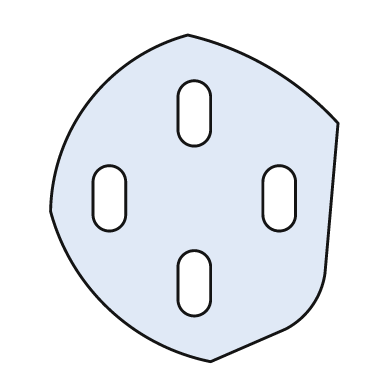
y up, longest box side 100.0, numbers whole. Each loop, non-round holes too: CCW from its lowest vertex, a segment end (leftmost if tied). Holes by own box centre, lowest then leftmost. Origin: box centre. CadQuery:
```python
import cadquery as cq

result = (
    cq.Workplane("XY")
    .moveTo(5.0, -50.0)
    .lineTo(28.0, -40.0)
    .threePointArc((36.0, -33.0), (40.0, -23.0))
    .lineTo(44.0, 23.0)
    .threePointArc((23.0, 40.0), (-2.0, 50.0))
    .threePointArc((-32.0, 30.0), (-44.0, -4.0))
    .threePointArc((-26.0, -34.0), (5.0, -50.0))
    .close()
    .moveTo(-5.0, -31.0)
    .threePointArc((0.0, -36.0), (5.0, -31.0))
    .lineTo(5.0, -21.0)
    .threePointArc((0.0, -16.0), (-5.0, -21.0))
    .close()
    .moveTo(-31.0, -5.0)
    .threePointArc((-26.0, -10.0), (-21.0, -5.0))
    .lineTo(-21.0, 5.0)
    .threePointArc((-26.0, 10.0), (-31.0, 5.0))
    .close()
    .moveTo(21.0, -5.0)
    .threePointArc((26.0, -10.0), (31.0, -5.0))
    .lineTo(31.0, 5.0)
    .threePointArc((26.0, 10.0), (21.0, 5.0))
    .close()
    .moveTo(-5.0, 21.0)
    .threePointArc((0.0, 16.0), (5.0, 21.0))
    .lineTo(5.0, 31.0)
    .threePointArc((0.0, 36.0), (-5.0, 31.0))
    .close()
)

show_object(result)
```